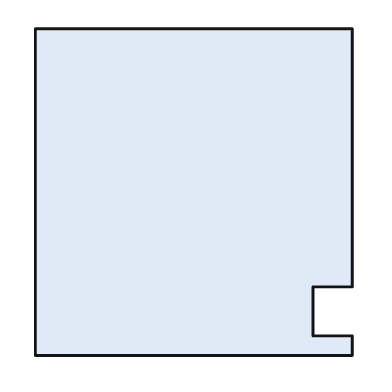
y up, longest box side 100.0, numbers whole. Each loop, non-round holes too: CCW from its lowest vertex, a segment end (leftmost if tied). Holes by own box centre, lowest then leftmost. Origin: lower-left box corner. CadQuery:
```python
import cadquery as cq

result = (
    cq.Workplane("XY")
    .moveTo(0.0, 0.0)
    .lineTo(97.0, 0.0)
    .lineTo(97.0, 6.0)
    .lineTo(85.0, 6.0)
    .lineTo(85.0, 21.0)
    .lineTo(97.0, 21.0)
    .lineTo(97.0, 100.0)
    .lineTo(0.0, 100.0)
    .close()
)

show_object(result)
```